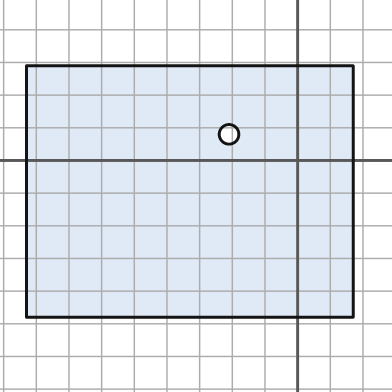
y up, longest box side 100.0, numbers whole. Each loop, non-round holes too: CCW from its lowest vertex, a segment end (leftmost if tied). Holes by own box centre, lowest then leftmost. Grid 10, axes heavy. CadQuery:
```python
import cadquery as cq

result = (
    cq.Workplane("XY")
    .moveTo(-83.0, -48.0)
    .lineTo(17.0, -48.0)
    .lineTo(17.0, 29.0)
    .lineTo(-83.0, 29.0)
    .close()
    .moveTo(-21.0, 8.0)
    .circle(3.0)
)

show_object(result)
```